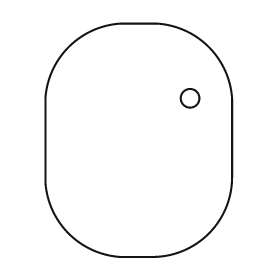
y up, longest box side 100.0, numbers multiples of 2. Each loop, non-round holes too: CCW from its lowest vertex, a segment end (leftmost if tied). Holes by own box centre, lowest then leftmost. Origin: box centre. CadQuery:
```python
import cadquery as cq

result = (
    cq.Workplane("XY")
    .moveTo(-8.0, -50.0)
    .lineTo(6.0, -50.0)
    .threePointArc((30.0, -40.0), (40.0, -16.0))
    .lineTo(40.0, 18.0)
    .threePointArc((30.0, 40.0), (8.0, 50.0))
    .lineTo(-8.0, 50.0)
    .threePointArc((-30.0, 40.0), (-40.0, 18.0))
    .lineTo(-40.0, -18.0)
    .threePointArc((-30.0, -40.0), (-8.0, -50.0))
    .close()
    .moveTo(22.0, 18.0)
    .circle(4.0)
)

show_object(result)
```